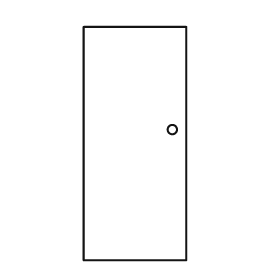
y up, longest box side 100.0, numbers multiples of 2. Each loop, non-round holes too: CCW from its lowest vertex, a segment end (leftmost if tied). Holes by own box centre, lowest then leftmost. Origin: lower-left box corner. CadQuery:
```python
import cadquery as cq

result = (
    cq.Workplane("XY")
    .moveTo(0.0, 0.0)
    .lineTo(44.0, 0.0)
    .lineTo(44.0, 100.0)
    .lineTo(0.0, 100.0)
    .close()
    .moveTo(38.0, 56.0)
    .circle(2.0)
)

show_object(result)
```